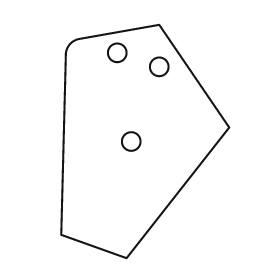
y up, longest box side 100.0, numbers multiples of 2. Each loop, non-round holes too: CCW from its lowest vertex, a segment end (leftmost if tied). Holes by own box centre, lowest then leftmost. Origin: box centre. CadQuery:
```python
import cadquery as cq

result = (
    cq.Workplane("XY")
    .moveTo(-8.0, -50.0)
    .lineTo(36.0, 6.0)
    .lineTo(6.0, 50.0)
    .lineTo(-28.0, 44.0)
    .threePointArc((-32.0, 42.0), (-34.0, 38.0))
    .lineTo(-36.0, -40.0)
    .close()
    .moveTo(-6.0, 0.0)
    .circle(4.0)
    .moveTo(6.0, 32.0)
    .circle(4.0)
    .moveTo(-12.0, 38.0)
    .circle(4.0)
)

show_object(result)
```